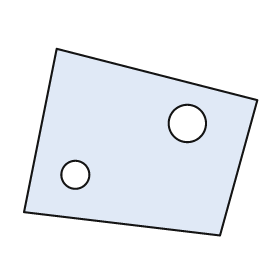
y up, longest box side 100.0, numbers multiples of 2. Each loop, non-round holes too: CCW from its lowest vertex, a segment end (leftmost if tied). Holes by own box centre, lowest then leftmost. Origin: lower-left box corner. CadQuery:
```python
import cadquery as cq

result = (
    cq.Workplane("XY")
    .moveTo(84.0, 0.0)
    .lineTo(100.0, 58.0)
    .lineTo(14.0, 80.0)
    .lineTo(0.0, 10.0)
    .close()
    .moveTo(22.0, 26.0)
    .circle(6.0)
    .moveTo(70.0, 48.0)
    .circle(8.0)
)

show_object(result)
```